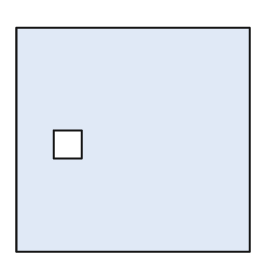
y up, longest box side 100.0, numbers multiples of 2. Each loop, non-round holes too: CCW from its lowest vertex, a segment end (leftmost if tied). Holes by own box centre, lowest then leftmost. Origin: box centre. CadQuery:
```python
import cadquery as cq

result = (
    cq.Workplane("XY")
    .moveTo(-50.0, -48.0)
    .lineTo(50.0, -48.0)
    .lineTo(50.0, 48.0)
    .lineTo(-50.0, 48.0)
    .close()
    .moveTo(-34.0, -8.0)
    .lineTo(-22.0, -8.0)
    .lineTo(-22.0, 4.0)
    .lineTo(-34.0, 4.0)
    .close()
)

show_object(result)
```